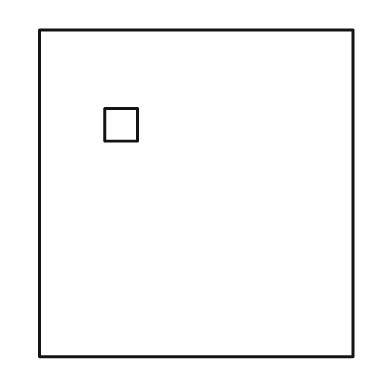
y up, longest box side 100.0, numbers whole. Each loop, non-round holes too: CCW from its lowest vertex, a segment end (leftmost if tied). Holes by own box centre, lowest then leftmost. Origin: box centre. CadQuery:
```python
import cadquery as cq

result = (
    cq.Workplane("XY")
    .moveTo(-48.0, -50.0)
    .lineTo(48.0, -50.0)
    .lineTo(48.0, 50.0)
    .lineTo(-48.0, 50.0)
    .close()
    .moveTo(-28.0, 16.0)
    .lineTo(-18.0, 16.0)
    .lineTo(-18.0, 26.0)
    .lineTo(-28.0, 26.0)
    .close()
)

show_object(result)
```